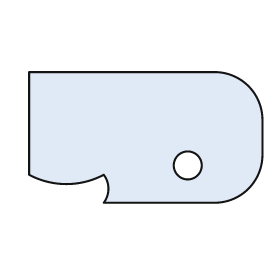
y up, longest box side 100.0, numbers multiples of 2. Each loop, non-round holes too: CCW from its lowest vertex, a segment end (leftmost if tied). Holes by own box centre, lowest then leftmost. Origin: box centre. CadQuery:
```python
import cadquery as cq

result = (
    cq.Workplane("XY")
    .moveTo(-18.0, -28.0)
    .lineTo(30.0, -28.0)
    .threePointArc((44.0, -22.0), (50.0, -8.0))
    .lineTo(50.0, 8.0)
    .threePointArc((44.0, 22.0), (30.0, 28.0))
    .lineTo(-50.0, 28.0)
    .lineTo(-50.0, -16.0)
    .threePointArc((-34.0, -20.0), (-18.0, -16.0))
    .threePointArc((-16.0, -22.0), (-18.0, -28.0))
    .close()
    .moveTo(18.0, -12.0)
    .circle(6.0)
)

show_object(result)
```